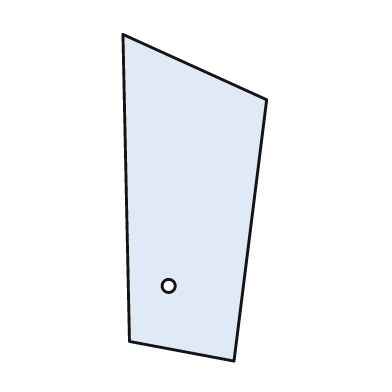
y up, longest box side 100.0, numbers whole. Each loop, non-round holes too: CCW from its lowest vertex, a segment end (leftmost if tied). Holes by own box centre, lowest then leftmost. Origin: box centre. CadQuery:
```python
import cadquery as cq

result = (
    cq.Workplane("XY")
    .moveTo(12.0, -50.0)
    .lineTo(22.0, 30.0)
    .lineTo(-22.0, 50.0)
    .lineTo(-20.0, -44.0)
    .close()
    .moveTo(-8.0, -27.0)
    .circle(2.0)
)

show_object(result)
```